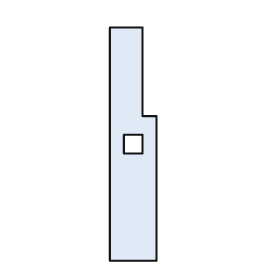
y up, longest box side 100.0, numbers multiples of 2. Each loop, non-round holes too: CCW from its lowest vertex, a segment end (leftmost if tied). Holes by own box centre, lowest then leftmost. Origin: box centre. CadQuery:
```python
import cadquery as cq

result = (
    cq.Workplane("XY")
    .moveTo(-10.0, -50.0)
    .lineTo(10.0, -50.0)
    .lineTo(10.0, 12.0)
    .lineTo(4.0, 12.0)
    .lineTo(4.0, 50.0)
    .lineTo(-10.0, 50.0)
    .close()
    .moveTo(-4.0, -4.0)
    .lineTo(4.0, -4.0)
    .lineTo(4.0, 4.0)
    .lineTo(-4.0, 4.0)
    .close()
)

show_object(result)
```